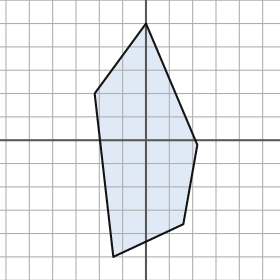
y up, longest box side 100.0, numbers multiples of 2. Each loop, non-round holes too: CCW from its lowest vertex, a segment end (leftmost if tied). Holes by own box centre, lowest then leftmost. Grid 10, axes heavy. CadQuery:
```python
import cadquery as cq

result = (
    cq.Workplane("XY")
    .moveTo(-14.0, -50.0)
    .lineTo(16.0, -36.0)
    .lineTo(22.0, -2.0)
    .lineTo(0.0, 50.0)
    .lineTo(-22.0, 20.0)
    .close()
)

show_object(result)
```